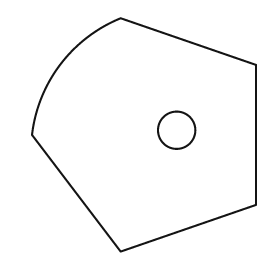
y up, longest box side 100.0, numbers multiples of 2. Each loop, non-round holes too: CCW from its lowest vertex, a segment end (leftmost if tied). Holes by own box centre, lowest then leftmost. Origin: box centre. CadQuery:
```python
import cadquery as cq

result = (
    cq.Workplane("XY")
    .moveTo(-10.0, -50.0)
    .lineTo(48.0, -30.0)
    .lineTo(48.0, 30.0)
    .lineTo(-10.0, 50.0)
    .threePointArc((-36.0, 30.0), (-48.0, 0.0))
    .close()
    .moveTo(14.0, 2.0)
    .circle(8.0)
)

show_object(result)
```